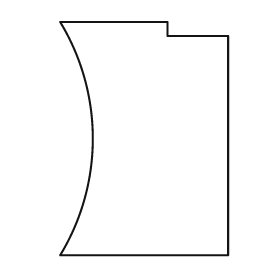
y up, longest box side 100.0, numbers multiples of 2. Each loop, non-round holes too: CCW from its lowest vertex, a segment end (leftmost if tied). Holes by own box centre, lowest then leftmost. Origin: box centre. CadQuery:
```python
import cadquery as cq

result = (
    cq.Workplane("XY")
    .moveTo(-36.0, -50.0)
    .lineTo(36.0, -50.0)
    .lineTo(36.0, 44.0)
    .lineTo(10.0, 44.0)
    .lineTo(10.0, 50.0)
    .lineTo(-36.0, 50.0)
    .threePointArc((-22.0, 0.0), (-36.0, -50.0))
    .close()
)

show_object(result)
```